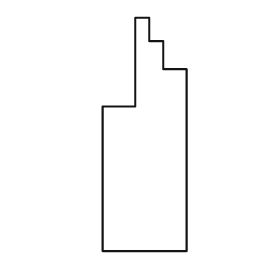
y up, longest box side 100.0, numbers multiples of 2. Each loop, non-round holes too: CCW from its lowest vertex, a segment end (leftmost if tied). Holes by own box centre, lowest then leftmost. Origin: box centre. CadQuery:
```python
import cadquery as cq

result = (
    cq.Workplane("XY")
    .moveTo(-18.0, -50.0)
    .lineTo(18.0, -50.0)
    .lineTo(18.0, 28.0)
    .lineTo(8.0, 28.0)
    .lineTo(8.0, 40.0)
    .lineTo(2.0, 40.0)
    .lineTo(2.0, 50.0)
    .lineTo(-4.0, 50.0)
    .lineTo(-4.0, 12.0)
    .lineTo(-18.0, 12.0)
    .close()
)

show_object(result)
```